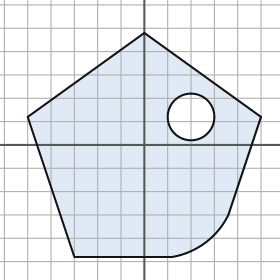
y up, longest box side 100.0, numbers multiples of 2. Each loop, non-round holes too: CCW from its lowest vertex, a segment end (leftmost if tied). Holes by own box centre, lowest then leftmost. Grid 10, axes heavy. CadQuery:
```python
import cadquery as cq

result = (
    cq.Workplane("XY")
    .moveTo(-30.0, -48.0)
    .lineTo(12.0, -48.0)
    .threePointArc((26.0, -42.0), (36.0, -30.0))
    .lineTo(50.0, 12.0)
    .lineTo(0.0, 48.0)
    .lineTo(-50.0, 12.0)
    .close()
    .moveTo(20.0, 12.0)
    .circle(10.0)
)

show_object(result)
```